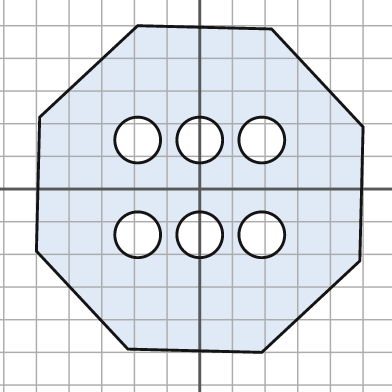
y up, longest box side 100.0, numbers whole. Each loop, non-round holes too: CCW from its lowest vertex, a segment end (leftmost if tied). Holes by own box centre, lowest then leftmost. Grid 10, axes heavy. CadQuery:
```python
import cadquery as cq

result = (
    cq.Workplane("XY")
    .moveTo(19.0, -50.0)
    .lineTo(49.0, -22.0)
    .lineTo(50.0, 19.0)
    .lineTo(22.0, 49.0)
    .lineTo(-19.0, 50.0)
    .lineTo(-49.0, 22.0)
    .lineTo(-50.0, -19.0)
    .lineTo(-22.0, -49.0)
    .close()
    .moveTo(-19.0, -14.0)
    .circle(7.0)
    .moveTo(0.0, -14.0)
    .circle(7.0)
    .moveTo(19.0, -14.0)
    .circle(7.0)
    .moveTo(-19.0, 15.0)
    .circle(7.0)
    .moveTo(0.0, 15.0)
    .circle(7.0)
    .moveTo(19.0, 15.0)
    .circle(7.0)
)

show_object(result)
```